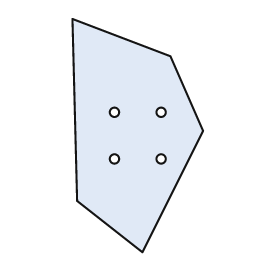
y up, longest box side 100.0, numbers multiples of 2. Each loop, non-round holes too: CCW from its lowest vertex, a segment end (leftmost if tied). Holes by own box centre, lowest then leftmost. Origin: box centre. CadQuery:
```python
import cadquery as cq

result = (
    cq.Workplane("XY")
    .moveTo(2.0, -50.0)
    .lineTo(28.0, 2.0)
    .lineTo(14.0, 34.0)
    .lineTo(-28.0, 50.0)
    .lineTo(-26.0, -28.0)
    .close()
    .moveTo(-10.0, -10.0)
    .circle(2.0)
    .moveTo(10.0, -10.0)
    .circle(2.0)
    .moveTo(-10.0, 10.0)
    .circle(2.0)
    .moveTo(10.0, 10.0)
    .circle(2.0)
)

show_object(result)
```